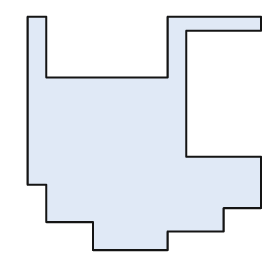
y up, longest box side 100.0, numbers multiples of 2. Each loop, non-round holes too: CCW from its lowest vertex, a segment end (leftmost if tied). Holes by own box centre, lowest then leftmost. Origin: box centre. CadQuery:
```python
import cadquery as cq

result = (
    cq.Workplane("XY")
    .moveTo(-22.0, -50.0)
    .lineTo(10.0, -50.0)
    .lineTo(10.0, -42.0)
    .lineTo(34.0, -42.0)
    .lineTo(34.0, -32.0)
    .lineTo(50.0, -32.0)
    .lineTo(50.0, -10.0)
    .lineTo(18.0, -10.0)
    .lineTo(18.0, 44.0)
    .lineTo(50.0, 44.0)
    .lineTo(50.0, 50.0)
    .lineTo(10.0, 50.0)
    .lineTo(10.0, 24.0)
    .lineTo(-42.0, 24.0)
    .lineTo(-42.0, 50.0)
    .lineTo(-50.0, 50.0)
    .lineTo(-50.0, -22.0)
    .lineTo(-42.0, -22.0)
    .lineTo(-42.0, -38.0)
    .lineTo(-22.0, -38.0)
    .close()
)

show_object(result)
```